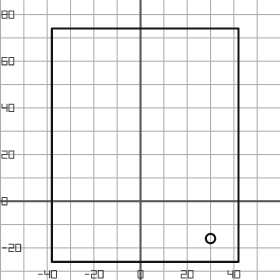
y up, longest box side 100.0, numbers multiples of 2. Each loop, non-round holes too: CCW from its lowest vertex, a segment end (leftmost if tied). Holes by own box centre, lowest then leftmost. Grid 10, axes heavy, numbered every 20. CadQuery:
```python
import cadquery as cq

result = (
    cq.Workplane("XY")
    .moveTo(-38.0, -26.0)
    .lineTo(42.0, -26.0)
    .lineTo(42.0, 74.0)
    .lineTo(-38.0, 74.0)
    .close()
    .moveTo(30.0, -16.0)
    .circle(2.0)
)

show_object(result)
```